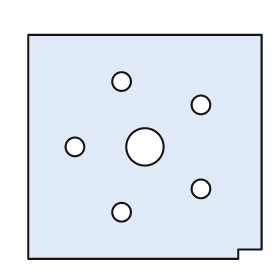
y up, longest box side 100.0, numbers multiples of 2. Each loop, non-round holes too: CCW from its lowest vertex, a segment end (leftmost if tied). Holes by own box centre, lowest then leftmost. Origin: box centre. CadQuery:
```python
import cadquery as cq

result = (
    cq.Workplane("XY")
    .moveTo(-50.0, -48.0)
    .lineTo(40.0, -48.0)
    .lineTo(40.0, -44.0)
    .lineTo(50.0, -44.0)
    .lineTo(50.0, 48.0)
    .lineTo(-50.0, 48.0)
    .close()
    .moveTo(-10.0, -28.0)
    .circle(4.0)
    .moveTo(24.0, -18.0)
    .circle(4.0)
    .moveTo(-30.0, 0.0)
    .circle(4.0)
    .moveTo(0.0, 0.0)
    .circle(8.0)
    .moveTo(24.0, 18.0)
    .circle(4.0)
    .moveTo(-10.0, 28.0)
    .circle(4.0)
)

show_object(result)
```